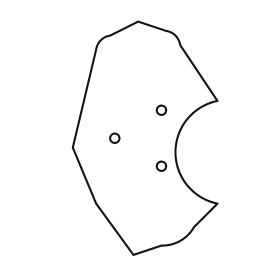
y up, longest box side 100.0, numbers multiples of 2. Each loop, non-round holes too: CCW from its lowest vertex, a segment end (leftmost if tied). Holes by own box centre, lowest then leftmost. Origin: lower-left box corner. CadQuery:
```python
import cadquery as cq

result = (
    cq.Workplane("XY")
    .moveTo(26.0, 0.0)
    .lineTo(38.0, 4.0)
    .threePointArc((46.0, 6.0), (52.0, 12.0))
    .lineTo(62.0, 22.0)
    .threePointArc((44.0, 44.0), (62.0, 66.0))
    .lineTo(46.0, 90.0)
    .threePointArc((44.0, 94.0), (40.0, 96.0))
    .lineTo(28.0, 100.0)
    .lineTo(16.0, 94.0)
    .threePointArc((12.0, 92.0), (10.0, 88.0))
    .lineTo(0.0, 46.0)
    .lineTo(10.0, 22.0)
    .close()
    .moveTo(38.0, 38.0)
    .circle(2.0)
    .moveTo(18.0, 50.0)
    .circle(2.0)
    .moveTo(38.0, 62.0)
    .circle(2.0)
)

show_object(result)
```